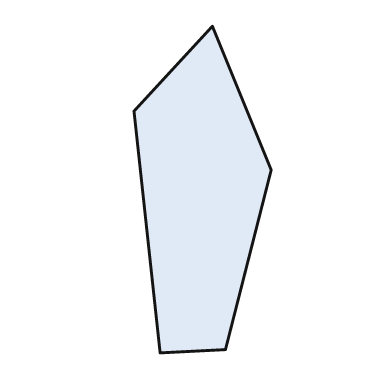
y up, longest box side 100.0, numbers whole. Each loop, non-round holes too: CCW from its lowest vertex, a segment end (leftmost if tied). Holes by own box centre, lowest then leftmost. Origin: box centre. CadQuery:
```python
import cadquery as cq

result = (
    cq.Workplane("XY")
    .moveTo(-13.0, -50.0)
    .lineTo(7.0, -49.0)
    .lineTo(21.0, 6.0)
    .lineTo(3.0, 50.0)
    .lineTo(-21.0, 24.0)
    .close()
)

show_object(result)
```